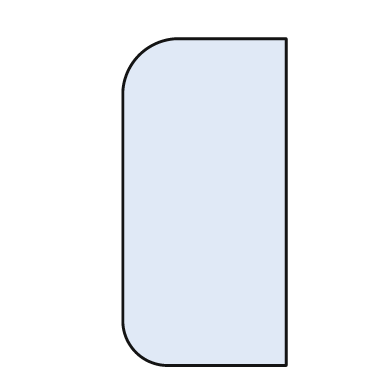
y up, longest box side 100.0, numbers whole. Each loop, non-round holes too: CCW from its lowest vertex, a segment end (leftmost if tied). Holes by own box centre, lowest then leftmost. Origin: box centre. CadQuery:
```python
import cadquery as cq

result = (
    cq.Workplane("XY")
    .moveTo(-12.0, -50.0)
    .lineTo(25.0, -50.0)
    .lineTo(25.0, 50.0)
    .lineTo(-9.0, 50.0)
    .threePointArc((-20.0, 45.0), (-25.0, 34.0))
    .lineTo(-25.0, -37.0)
    .threePointArc((-21.0, -46.0), (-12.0, -50.0))
    .close()
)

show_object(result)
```